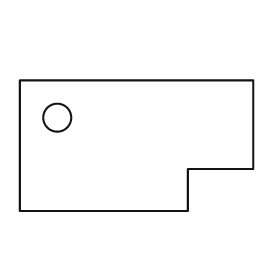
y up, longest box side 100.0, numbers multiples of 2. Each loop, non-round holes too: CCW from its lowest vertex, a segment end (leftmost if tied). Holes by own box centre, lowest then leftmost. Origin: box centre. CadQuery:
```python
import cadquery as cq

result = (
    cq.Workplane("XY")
    .moveTo(-50.0, -28.0)
    .lineTo(22.0, -28.0)
    .lineTo(22.0, -10.0)
    .lineTo(50.0, -10.0)
    .lineTo(50.0, 28.0)
    .lineTo(-50.0, 28.0)
    .close()
    .moveTo(-34.0, 12.0)
    .circle(6.0)
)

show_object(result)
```